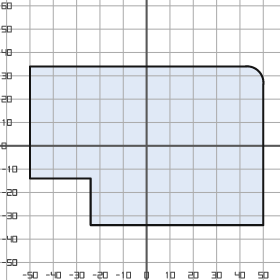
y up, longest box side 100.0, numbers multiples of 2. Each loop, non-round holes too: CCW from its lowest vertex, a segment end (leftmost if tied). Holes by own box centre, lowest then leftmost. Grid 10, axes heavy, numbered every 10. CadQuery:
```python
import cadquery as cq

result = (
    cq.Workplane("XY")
    .moveTo(-24.0, -34.0)
    .lineTo(50.0, -34.0)
    .lineTo(50.0, 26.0)
    .threePointArc((48.0, 32.0), (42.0, 34.0))
    .lineTo(-50.0, 34.0)
    .lineTo(-50.0, -14.0)
    .lineTo(-24.0, -14.0)
    .close()
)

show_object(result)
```